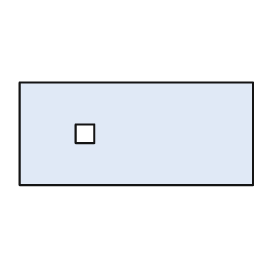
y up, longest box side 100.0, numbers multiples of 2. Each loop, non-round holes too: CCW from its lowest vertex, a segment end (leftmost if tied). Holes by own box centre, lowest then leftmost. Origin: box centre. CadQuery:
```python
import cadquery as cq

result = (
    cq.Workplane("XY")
    .moveTo(-50.0, -22.0)
    .lineTo(50.0, -22.0)
    .lineTo(50.0, 22.0)
    .lineTo(-50.0, 22.0)
    .close()
    .moveTo(-26.0, -4.0)
    .lineTo(-18.0, -4.0)
    .lineTo(-18.0, 4.0)
    .lineTo(-26.0, 4.0)
    .close()
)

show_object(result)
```